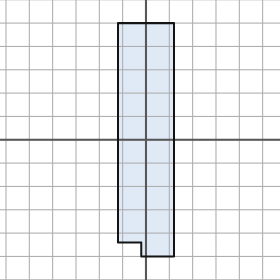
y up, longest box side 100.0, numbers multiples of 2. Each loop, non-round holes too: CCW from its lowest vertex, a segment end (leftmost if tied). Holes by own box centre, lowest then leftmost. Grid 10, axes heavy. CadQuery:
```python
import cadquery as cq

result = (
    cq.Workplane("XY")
    .moveTo(-2.0, -50.0)
    .lineTo(12.0, -50.0)
    .lineTo(12.0, 50.0)
    .lineTo(-12.0, 50.0)
    .lineTo(-12.0, -44.0)
    .lineTo(-2.0, -44.0)
    .close()
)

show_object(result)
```